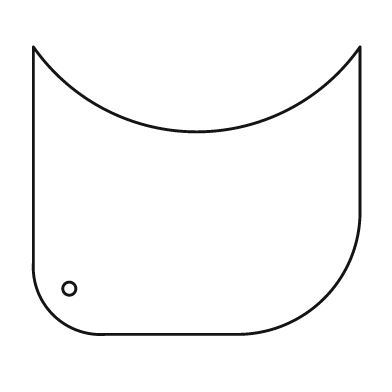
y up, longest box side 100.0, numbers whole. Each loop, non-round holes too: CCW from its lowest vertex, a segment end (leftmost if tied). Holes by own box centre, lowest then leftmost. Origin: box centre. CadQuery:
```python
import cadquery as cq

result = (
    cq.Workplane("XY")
    .moveTo(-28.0, -44.0)
    .lineTo(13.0, -44.0)
    .threePointArc((39.0, -33.0), (50.0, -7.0))
    .lineTo(50.0, 44.0)
    .threePointArc((0.0, 18.0), (-50.0, 44.0))
    .lineTo(-50.0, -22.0)
    .threePointArc((-44.0, -38.0), (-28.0, -44.0))
    .close()
    .moveTo(-39.0, -30.0)
    .circle(2.0)
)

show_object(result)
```